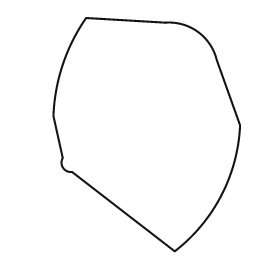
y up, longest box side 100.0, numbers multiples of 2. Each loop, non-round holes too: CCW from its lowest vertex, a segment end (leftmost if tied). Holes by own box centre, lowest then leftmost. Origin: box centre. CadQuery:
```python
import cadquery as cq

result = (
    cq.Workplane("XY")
    .moveTo(12.0, -50.0)
    .threePointArc((32.0, -26.0), (40.0, 4.0))
    .lineTo(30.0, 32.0)
    .threePointArc((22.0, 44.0), (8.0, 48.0))
    .lineTo(-26.0, 50.0)
    .threePointArc((-36.0, 30.0), (-40.0, 8.0))
    .lineTo(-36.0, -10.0)
    .threePointArc((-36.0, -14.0), (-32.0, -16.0))
    .close()
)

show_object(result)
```